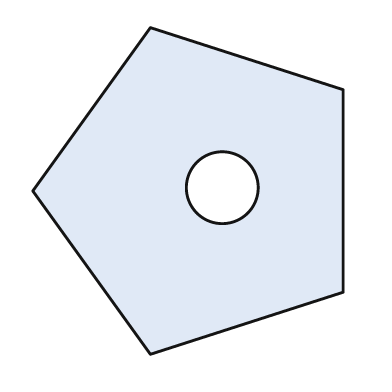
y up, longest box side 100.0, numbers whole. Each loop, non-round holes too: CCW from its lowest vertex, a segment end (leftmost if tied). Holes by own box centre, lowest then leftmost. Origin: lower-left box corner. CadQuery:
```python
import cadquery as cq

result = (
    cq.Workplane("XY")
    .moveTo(36.0, 0.0)
    .lineTo(95.0, 19.0)
    .lineTo(95.0, 81.0)
    .lineTo(36.0, 100.0)
    .lineTo(0.0, 50.0)
    .close()
    .moveTo(58.0, 51.0)
    .circle(11.0)
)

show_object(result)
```